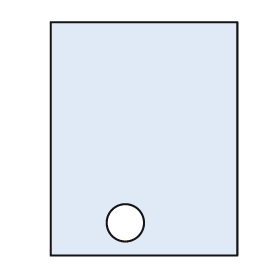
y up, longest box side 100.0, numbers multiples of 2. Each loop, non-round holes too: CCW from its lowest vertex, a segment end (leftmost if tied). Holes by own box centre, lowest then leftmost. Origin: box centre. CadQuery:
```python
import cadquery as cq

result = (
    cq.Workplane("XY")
    .moveTo(-40.0, -50.0)
    .lineTo(40.0, -50.0)
    .lineTo(40.0, 50.0)
    .lineTo(-40.0, 50.0)
    .close()
    .moveTo(-8.0, -36.0)
    .circle(8.0)
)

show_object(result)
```